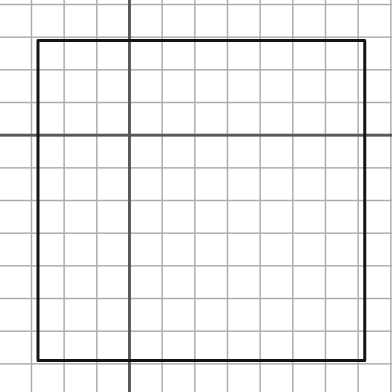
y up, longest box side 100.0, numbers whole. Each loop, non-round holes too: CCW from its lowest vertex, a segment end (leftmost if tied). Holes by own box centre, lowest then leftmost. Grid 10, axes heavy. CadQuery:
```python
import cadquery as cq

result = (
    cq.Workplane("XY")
    .moveTo(-28.0, -69.0)
    .lineTo(72.0, -69.0)
    .lineTo(72.0, 29.0)
    .lineTo(-28.0, 29.0)
    .close()
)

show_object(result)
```